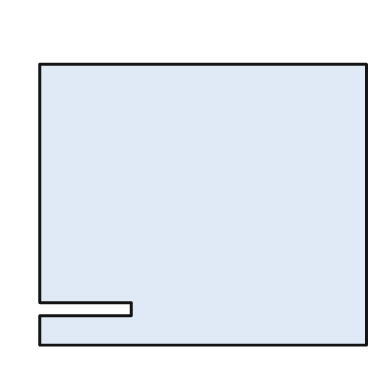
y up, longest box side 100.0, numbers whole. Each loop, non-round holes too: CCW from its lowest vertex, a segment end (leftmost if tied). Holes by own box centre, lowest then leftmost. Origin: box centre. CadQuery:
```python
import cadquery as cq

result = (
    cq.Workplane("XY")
    .moveTo(-50.0, -43.0)
    .lineTo(50.0, -43.0)
    .lineTo(50.0, 43.0)
    .lineTo(-50.0, 43.0)
    .lineTo(-50.0, -30.0)
    .lineTo(-22.0, -30.0)
    .lineTo(-22.0, -34.0)
    .lineTo(-50.0, -34.0)
    .close()
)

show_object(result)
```